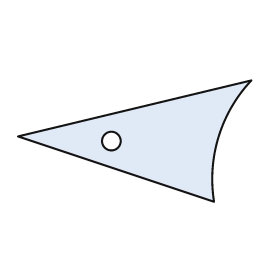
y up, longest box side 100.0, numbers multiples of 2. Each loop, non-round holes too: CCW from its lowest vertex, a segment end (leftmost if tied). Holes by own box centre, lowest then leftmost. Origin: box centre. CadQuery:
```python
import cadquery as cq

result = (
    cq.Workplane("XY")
    .moveTo(34.0, -26.0)
    .threePointArc((36.0, 2.0), (50.0, 26.0))
    .lineTo(-50.0, 2.0)
    .close()
    .moveTo(-10.0, 0.0)
    .circle(4.0)
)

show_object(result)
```